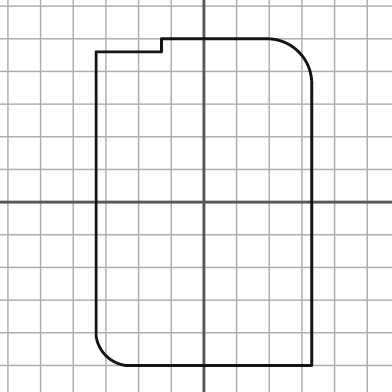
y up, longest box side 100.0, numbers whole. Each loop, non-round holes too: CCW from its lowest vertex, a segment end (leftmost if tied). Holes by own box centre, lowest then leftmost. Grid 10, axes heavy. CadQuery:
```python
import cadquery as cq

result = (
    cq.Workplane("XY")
    .moveTo(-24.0, -50.0)
    .lineTo(33.0, -50.0)
    .lineTo(33.0, 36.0)
    .threePointArc((29.0, 46.0), (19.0, 50.0))
    .lineTo(-13.0, 50.0)
    .lineTo(-13.0, 46.0)
    .lineTo(-33.0, 46.0)
    .lineTo(-33.0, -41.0)
    .threePointArc((-30.0, -47.0), (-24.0, -50.0))
    .close()
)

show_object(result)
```